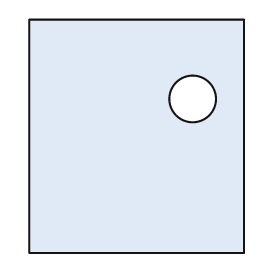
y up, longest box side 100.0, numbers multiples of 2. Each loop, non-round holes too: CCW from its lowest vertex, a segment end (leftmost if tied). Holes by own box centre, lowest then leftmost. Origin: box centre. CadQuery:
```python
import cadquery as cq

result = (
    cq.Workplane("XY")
    .moveTo(-46.0, -50.0)
    .lineTo(46.0, -50.0)
    .lineTo(46.0, 50.0)
    .lineTo(-46.0, 50.0)
    .close()
    .moveTo(24.0, 16.0)
    .circle(10.0)
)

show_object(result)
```